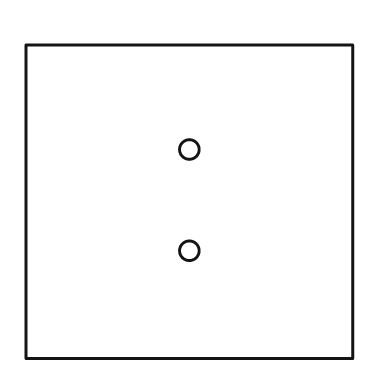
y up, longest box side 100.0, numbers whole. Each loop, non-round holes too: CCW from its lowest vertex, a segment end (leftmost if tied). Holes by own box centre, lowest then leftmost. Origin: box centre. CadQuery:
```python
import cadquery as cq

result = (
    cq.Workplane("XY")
    .moveTo(-50.0, -48.0)
    .lineTo(50.0, -48.0)
    .lineTo(50.0, 48.0)
    .lineTo(-50.0, 48.0)
    .close()
    .moveTo(0.0, -15.0)
    .circle(3.0)
    .moveTo(0.0, 16.0)
    .circle(3.0)
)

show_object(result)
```